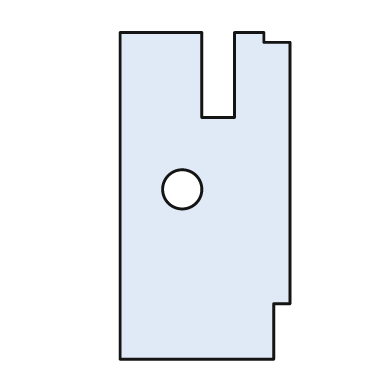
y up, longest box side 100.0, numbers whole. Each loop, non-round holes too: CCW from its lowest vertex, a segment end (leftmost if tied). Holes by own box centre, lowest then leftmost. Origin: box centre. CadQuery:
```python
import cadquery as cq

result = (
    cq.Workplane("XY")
    .moveTo(-26.0, -50.0)
    .lineTo(21.0, -50.0)
    .lineTo(21.0, -33.0)
    .lineTo(26.0, -33.0)
    .lineTo(26.0, 47.0)
    .lineTo(18.0, 47.0)
    .lineTo(18.0, 50.0)
    .lineTo(9.0, 50.0)
    .lineTo(9.0, 24.0)
    .lineTo(-1.0, 24.0)
    .lineTo(-1.0, 50.0)
    .lineTo(-26.0, 50.0)
    .close()
    .moveTo(-7.0, 2.0)
    .circle(6.0)
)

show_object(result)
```